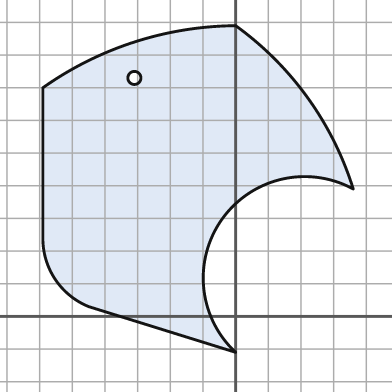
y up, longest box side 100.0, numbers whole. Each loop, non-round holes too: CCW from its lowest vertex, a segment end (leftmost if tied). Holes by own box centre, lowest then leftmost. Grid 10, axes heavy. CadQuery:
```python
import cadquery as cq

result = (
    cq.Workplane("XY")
    .moveTo(0.0, -11.0)
    .threePointArc((-4.0, 30.0), (36.0, 39.0))
    .threePointArc((22.0, 67.0), (0.0, 89.0))
    .threePointArc((-31.0, 84.0), (-59.0, 70.0))
    .lineTo(-59.0, 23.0)
    .threePointArc((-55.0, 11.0), (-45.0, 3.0))
    .close()
    .moveTo(-31.0, 73.0)
    .circle(2.0)
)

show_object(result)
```